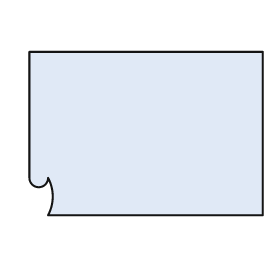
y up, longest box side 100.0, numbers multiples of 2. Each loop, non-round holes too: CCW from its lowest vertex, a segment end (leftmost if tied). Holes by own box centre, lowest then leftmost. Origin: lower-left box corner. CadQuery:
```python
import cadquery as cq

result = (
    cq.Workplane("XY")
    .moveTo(8.0, 0.0)
    .lineTo(100.0, 0.0)
    .lineTo(100.0, 70.0)
    .lineTo(0.0, 70.0)
    .lineTo(0.0, 16.0)
    .threePointArc((4.0, 12.0), (8.0, 16.0))
    .threePointArc((10.0, 8.0), (8.0, 0.0))
    .close()
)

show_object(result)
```